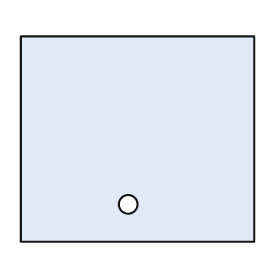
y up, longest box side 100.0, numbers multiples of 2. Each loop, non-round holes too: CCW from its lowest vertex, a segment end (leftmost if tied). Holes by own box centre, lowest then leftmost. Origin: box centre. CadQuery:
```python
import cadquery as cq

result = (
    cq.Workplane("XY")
    .moveTo(-50.0, -44.0)
    .lineTo(50.0, -44.0)
    .lineTo(50.0, 44.0)
    .lineTo(-50.0, 44.0)
    .close()
    .moveTo(-4.0, -28.0)
    .circle(4.0)
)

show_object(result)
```